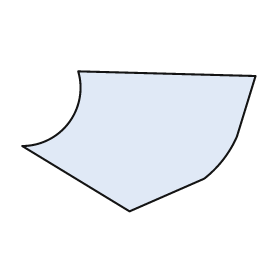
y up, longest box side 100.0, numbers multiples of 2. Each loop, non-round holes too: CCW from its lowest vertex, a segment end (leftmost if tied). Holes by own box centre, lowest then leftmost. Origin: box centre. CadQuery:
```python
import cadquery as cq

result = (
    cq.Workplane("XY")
    .moveTo(-4.0, -30.0)
    .lineTo(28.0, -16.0)
    .threePointArc((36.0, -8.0), (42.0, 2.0))
    .lineTo(50.0, 28.0)
    .lineTo(-26.0, 30.0)
    .threePointArc((-30.0, 8.0), (-50.0, -2.0))
    .close()
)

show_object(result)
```